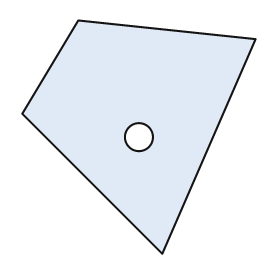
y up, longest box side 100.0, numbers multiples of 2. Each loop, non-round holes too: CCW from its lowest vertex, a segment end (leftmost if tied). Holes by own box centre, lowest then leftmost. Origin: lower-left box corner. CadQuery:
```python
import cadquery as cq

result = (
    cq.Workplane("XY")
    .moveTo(60.0, 0.0)
    .lineTo(100.0, 92.0)
    .lineTo(24.0, 100.0)
    .lineTo(0.0, 60.0)
    .close()
    .moveTo(50.0, 50.0)
    .circle(6.0)
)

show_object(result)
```